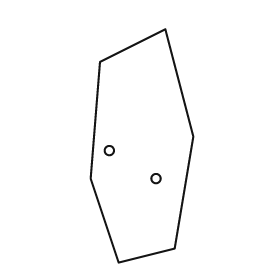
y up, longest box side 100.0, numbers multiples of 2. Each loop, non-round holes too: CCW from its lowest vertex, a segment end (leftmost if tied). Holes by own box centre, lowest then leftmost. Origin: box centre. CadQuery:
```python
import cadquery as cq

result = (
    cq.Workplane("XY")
    .moveTo(-10.0, -50.0)
    .lineTo(14.0, -44.0)
    .lineTo(22.0, 4.0)
    .lineTo(10.0, 50.0)
    .lineTo(-18.0, 36.0)
    .lineTo(-22.0, -14.0)
    .close()
    .moveTo(6.0, -14.0)
    .circle(2.0)
    .moveTo(-14.0, -2.0)
    .circle(2.0)
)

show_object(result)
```